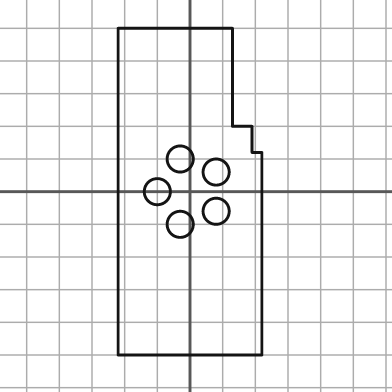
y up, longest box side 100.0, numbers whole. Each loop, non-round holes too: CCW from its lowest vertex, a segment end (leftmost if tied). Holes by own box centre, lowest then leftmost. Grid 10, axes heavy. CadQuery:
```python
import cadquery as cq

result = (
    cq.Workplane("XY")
    .moveTo(-22.0, -50.0)
    .lineTo(22.0, -50.0)
    .lineTo(22.0, 12.0)
    .lineTo(19.0, 12.0)
    .lineTo(19.0, 20.0)
    .lineTo(13.0, 20.0)
    .lineTo(13.0, 50.0)
    .lineTo(-22.0, 50.0)
    .close()
    .moveTo(-3.0, -10.0)
    .circle(4.0)
    .moveTo(8.0, -6.0)
    .circle(4.0)
    .moveTo(-10.0, 0.0)
    .circle(4.0)
    .moveTo(8.0, 6.0)
    .circle(4.0)
    .moveTo(-3.0, 10.0)
    .circle(4.0)
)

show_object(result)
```